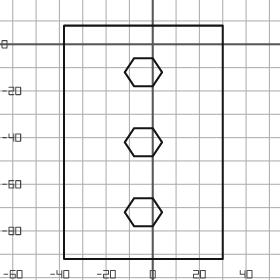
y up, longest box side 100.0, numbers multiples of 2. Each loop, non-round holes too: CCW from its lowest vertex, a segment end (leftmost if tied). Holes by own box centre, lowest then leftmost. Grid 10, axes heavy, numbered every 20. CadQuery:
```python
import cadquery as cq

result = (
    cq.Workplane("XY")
    .moveTo(-38.0, -92.0)
    .lineTo(30.0, -92.0)
    .lineTo(30.0, 8.0)
    .lineTo(-38.0, 8.0)
    .close()
    .moveTo(-8.0, -78.0)
    .lineTo(0.0, -78.0)
    .lineTo(4.0, -72.0)
    .lineTo(0.0, -66.0)
    .lineTo(-8.0, -66.0)
    .lineTo(-12.0, -72.0)
    .close()
    .moveTo(-8.0, -48.0)
    .lineTo(0.0, -48.0)
    .lineTo(4.0, -42.0)
    .lineTo(0.0, -36.0)
    .lineTo(-8.0, -36.0)
    .lineTo(-12.0, -42.0)
    .close()
    .moveTo(-8.0, -18.0)
    .lineTo(0.0, -18.0)
    .lineTo(4.0, -12.0)
    .lineTo(0.0, -6.0)
    .lineTo(-8.0, -6.0)
    .lineTo(-12.0, -12.0)
    .close()
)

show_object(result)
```